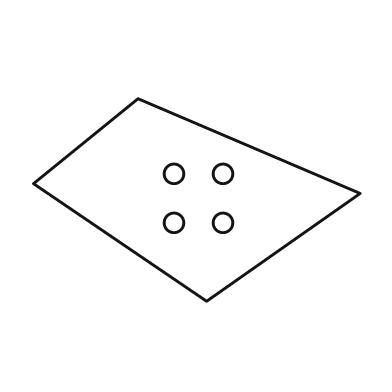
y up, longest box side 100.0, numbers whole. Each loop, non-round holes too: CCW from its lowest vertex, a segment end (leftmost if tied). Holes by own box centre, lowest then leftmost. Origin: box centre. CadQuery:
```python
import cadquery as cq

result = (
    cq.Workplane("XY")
    .moveTo(3.0, -31.0)
    .lineTo(50.0, 2.0)
    .lineTo(-18.0, 31.0)
    .lineTo(-50.0, 5.0)
    .close()
    .moveTo(-7.0, -7.0)
    .circle(3.0)
    .moveTo(8.0, -7.0)
    .circle(3.0)
    .moveTo(-7.0, 8.0)
    .circle(3.0)
    .moveTo(8.0, 8.0)
    .circle(3.0)
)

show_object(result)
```